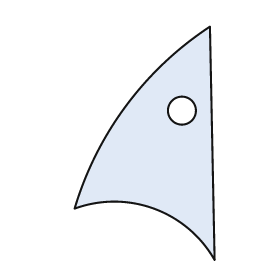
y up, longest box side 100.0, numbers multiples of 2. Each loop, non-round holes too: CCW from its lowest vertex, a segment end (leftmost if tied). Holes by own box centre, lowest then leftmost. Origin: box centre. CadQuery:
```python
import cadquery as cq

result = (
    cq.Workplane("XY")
    .moveTo(30.0, -50.0)
    .lineTo(28.0, 50.0)
    .threePointArc((-8.0, 16.0), (-30.0, -28.0))
    .threePointArc((4.0, -28.0), (30.0, -50.0))
    .close()
    .moveTo(16.0, 14.0)
    .circle(6.0)
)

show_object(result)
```